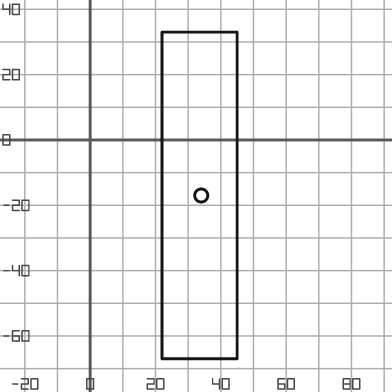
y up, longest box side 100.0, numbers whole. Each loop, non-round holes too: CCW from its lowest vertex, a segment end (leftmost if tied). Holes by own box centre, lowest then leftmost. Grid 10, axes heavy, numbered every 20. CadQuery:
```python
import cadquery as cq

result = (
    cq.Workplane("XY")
    .moveTo(22.0, -67.0)
    .lineTo(45.0, -67.0)
    .lineTo(45.0, 33.0)
    .lineTo(22.0, 33.0)
    .close()
    .moveTo(34.0, -17.0)
    .circle(2.0)
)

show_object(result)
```